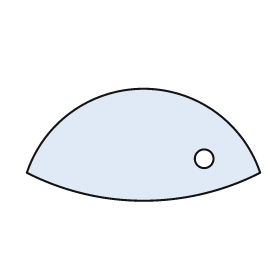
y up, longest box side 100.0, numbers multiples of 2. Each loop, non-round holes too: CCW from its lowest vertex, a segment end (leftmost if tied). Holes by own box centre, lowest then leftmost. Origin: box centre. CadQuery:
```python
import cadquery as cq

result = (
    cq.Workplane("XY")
    .moveTo(-50.0, -12.0)
    .threePointArc((0.0, -24.0), (50.0, -12.0))
    .threePointArc((0.0, 24.0), (-50.0, -12.0))
    .close()
    .moveTo(26.0, -6.0)
    .circle(4.0)
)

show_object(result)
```